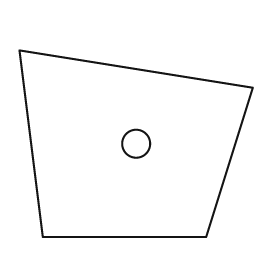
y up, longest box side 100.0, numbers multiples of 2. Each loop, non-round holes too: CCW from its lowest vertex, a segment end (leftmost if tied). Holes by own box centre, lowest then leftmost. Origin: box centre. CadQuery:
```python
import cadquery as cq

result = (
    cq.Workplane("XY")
    .moveTo(-40.0, -40.0)
    .lineTo(30.0, -40.0)
    .lineTo(50.0, 24.0)
    .lineTo(-50.0, 40.0)
    .close()
    .moveTo(0.0, 0.0)
    .circle(6.0)
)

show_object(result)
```